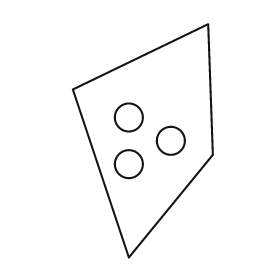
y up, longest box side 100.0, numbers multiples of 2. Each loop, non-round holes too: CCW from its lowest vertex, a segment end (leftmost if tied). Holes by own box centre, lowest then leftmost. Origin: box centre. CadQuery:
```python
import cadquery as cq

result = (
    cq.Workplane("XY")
    .moveTo(-6.0, -50.0)
    .lineTo(30.0, -6.0)
    .lineTo(28.0, 50.0)
    .lineTo(-30.0, 22.0)
    .close()
    .moveTo(-6.0, -10.0)
    .circle(6.0)
    .moveTo(12.0, 0.0)
    .circle(6.0)
    .moveTo(-6.0, 10.0)
    .circle(6.0)
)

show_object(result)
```